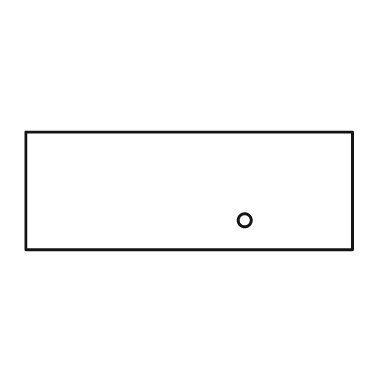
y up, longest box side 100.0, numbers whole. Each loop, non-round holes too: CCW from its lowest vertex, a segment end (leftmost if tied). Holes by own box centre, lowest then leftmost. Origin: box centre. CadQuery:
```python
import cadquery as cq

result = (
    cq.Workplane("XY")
    .moveTo(-50.0, -18.0)
    .lineTo(50.0, -18.0)
    .lineTo(50.0, 18.0)
    .lineTo(-50.0, 18.0)
    .close()
    .moveTo(17.0, -9.0)
    .circle(2.0)
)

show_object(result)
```